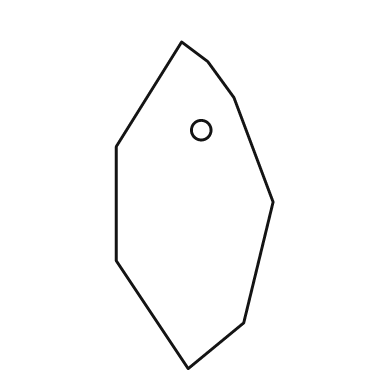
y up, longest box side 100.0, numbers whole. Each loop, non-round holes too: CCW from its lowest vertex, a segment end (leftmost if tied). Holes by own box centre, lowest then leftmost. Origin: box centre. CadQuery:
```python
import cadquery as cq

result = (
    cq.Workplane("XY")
    .moveTo(-2.0, -50.0)
    .lineTo(15.0, -36.0)
    .lineTo(24.0, 1.0)
    .lineTo(12.0, 33.0)
    .lineTo(4.0, 44.0)
    .lineTo(-4.0, 50.0)
    .lineTo(-24.0, 18.0)
    .lineTo(-24.0, -17.0)
    .close()
    .moveTo(2.0, 23.0)
    .circle(3.0)
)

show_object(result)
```